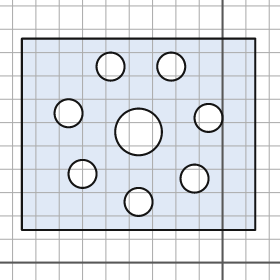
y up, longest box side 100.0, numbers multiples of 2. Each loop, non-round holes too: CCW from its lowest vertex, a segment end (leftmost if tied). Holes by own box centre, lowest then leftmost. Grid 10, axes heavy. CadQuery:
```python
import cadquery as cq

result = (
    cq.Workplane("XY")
    .moveTo(-86.0, 14.0)
    .lineTo(14.0, 14.0)
    .lineTo(14.0, 96.0)
    .lineTo(-86.0, 96.0)
    .close()
    .moveTo(-36.0, 26.0)
    .circle(6.0)
    .moveTo(-12.0, 36.0)
    .circle(6.0)
    .moveTo(-60.0, 38.0)
    .circle(6.0)
    .moveTo(-36.0, 56.0)
    .circle(10.0)
    .moveTo(-6.0, 62.0)
    .circle(6.0)
    .moveTo(-66.0, 64.0)
    .circle(6.0)
    .moveTo(-48.0, 84.0)
    .circle(6.0)
    .moveTo(-22.0, 84.0)
    .circle(6.0)
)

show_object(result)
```